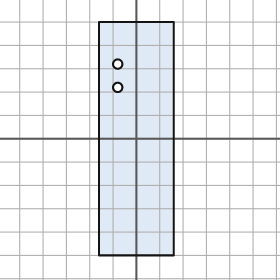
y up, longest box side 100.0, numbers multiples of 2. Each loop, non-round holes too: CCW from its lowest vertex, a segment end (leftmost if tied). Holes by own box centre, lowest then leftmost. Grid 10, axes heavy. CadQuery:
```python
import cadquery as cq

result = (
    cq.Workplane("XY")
    .moveTo(-16.0, -50.0)
    .lineTo(16.0, -50.0)
    .lineTo(16.0, 50.0)
    .lineTo(-16.0, 50.0)
    .close()
    .moveTo(-8.0, 22.0)
    .circle(2.0)
    .moveTo(-8.0, 32.0)
    .circle(2.0)
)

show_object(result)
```